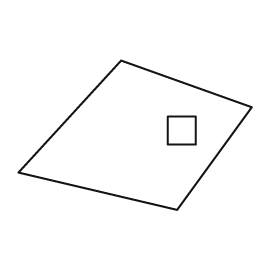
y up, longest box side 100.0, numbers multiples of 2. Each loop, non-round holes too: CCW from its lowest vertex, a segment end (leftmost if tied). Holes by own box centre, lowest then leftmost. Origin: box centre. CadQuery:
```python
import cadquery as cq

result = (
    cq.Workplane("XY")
    .moveTo(18.0, -32.0)
    .lineTo(50.0, 12.0)
    .lineTo(-6.0, 32.0)
    .lineTo(-50.0, -16.0)
    .close()
    .moveTo(14.0, -4.0)
    .lineTo(26.0, -4.0)
    .lineTo(26.0, 8.0)
    .lineTo(14.0, 8.0)
    .close()
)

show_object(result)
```